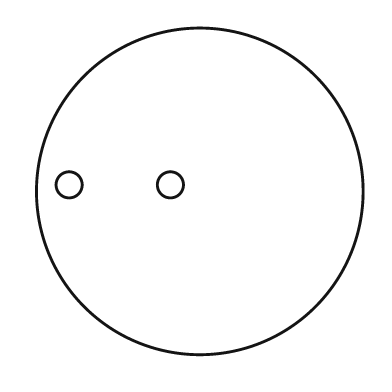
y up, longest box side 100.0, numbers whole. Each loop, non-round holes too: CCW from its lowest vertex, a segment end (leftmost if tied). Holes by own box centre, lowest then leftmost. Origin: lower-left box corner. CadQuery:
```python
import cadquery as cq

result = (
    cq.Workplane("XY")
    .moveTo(50.0, 50.0)
    .circle(50.0)
    .moveTo(10.0, 52.0)
    .circle(4.0)
    .moveTo(41.0, 52.0)
    .circle(4.0)
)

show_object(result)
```